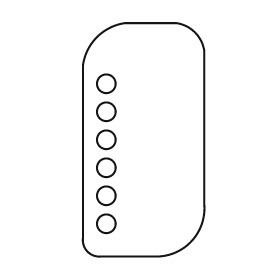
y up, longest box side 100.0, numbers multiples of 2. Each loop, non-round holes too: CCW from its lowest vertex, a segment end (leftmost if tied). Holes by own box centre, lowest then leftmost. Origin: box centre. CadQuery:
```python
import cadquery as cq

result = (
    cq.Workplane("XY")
    .moveTo(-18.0, -50.0)
    .lineTo(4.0, -50.0)
    .threePointArc((20.0, -44.0), (26.0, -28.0))
    .lineTo(26.0, 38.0)
    .threePointArc((22.0, 46.0), (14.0, 50.0))
    .lineTo(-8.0, 50.0)
    .threePointArc((-20.0, 44.0), (-26.0, 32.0))
    .lineTo(-26.0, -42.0)
    .threePointArc((-24.0, -48.0), (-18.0, -50.0))
    .close()
    .moveTo(-16.0, -36.0)
    .circle(4.0)
    .moveTo(-16.0, -24.0)
    .circle(4.0)
    .moveTo(-16.0, -12.0)
    .circle(4.0)
    .moveTo(-16.0, 0.0)
    .circle(4.0)
    .moveTo(-16.0, 12.0)
    .circle(4.0)
    .moveTo(-16.0, 24.0)
    .circle(4.0)
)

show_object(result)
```